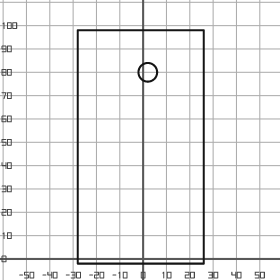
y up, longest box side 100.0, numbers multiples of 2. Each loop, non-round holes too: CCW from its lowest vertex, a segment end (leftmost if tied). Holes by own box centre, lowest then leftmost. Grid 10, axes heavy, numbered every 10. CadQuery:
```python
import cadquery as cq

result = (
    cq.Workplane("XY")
    .moveTo(-28.0, -2.0)
    .lineTo(26.0, -2.0)
    .lineTo(26.0, 98.0)
    .lineTo(-28.0, 98.0)
    .close()
    .moveTo(2.0, 80.0)
    .circle(4.0)
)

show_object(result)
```